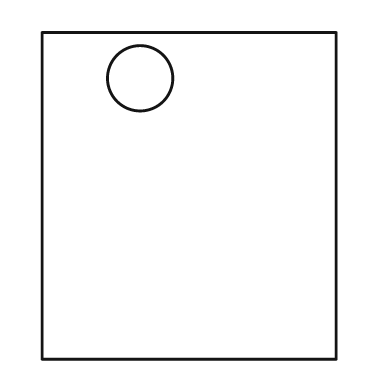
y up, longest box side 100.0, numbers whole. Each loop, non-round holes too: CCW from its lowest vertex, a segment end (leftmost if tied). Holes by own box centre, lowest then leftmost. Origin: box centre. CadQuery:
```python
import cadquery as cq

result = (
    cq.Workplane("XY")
    .moveTo(-45.0, -50.0)
    .lineTo(45.0, -50.0)
    .lineTo(45.0, 50.0)
    .lineTo(-45.0, 50.0)
    .close()
    .moveTo(-15.0, 36.0)
    .circle(10.0)
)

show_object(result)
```